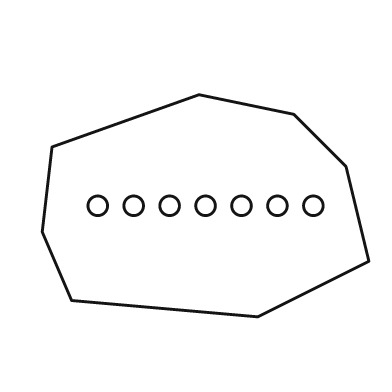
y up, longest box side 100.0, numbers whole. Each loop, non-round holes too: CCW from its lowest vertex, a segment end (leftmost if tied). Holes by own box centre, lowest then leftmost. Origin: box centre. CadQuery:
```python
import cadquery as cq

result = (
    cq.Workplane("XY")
    .moveTo(16.0, -34.0)
    .lineTo(50.0, -17.0)
    .lineTo(43.0, 12.0)
    .lineTo(27.0, 28.0)
    .lineTo(-2.0, 34.0)
    .lineTo(-47.0, 18.0)
    .lineTo(-50.0, -8.0)
    .lineTo(-41.0, -29.0)
    .close()
    .moveTo(-33.0, 0.0)
    .circle(3.0)
    .moveTo(-22.0, 0.0)
    .circle(3.0)
    .moveTo(-11.0, 0.0)
    .circle(3.0)
    .moveTo(0.0, 0.0)
    .circle(3.0)
    .moveTo(11.0, 0.0)
    .circle(3.0)
    .moveTo(22.0, 0.0)
    .circle(3.0)
    .moveTo(33.0, 0.0)
    .circle(3.0)
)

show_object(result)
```